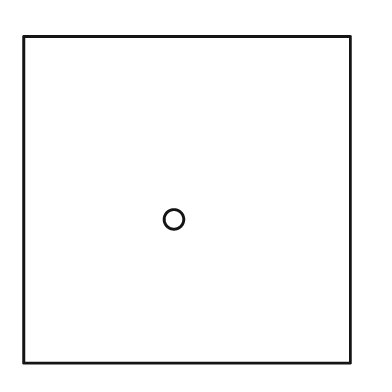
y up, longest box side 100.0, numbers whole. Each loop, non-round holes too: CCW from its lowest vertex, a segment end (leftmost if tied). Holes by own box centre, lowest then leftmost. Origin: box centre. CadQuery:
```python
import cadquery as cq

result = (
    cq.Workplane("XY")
    .moveTo(-50.0, -50.0)
    .lineTo(50.0, -50.0)
    .lineTo(50.0, 50.0)
    .lineTo(-50.0, 50.0)
    .close()
    .moveTo(-4.0, -6.0)
    .circle(3.0)
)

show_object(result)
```